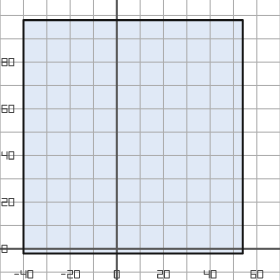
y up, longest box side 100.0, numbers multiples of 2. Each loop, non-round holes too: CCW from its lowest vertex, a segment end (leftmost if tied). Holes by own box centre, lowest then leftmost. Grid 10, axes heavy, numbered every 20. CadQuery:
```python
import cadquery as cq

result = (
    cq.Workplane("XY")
    .moveTo(-40.0, -2.0)
    .lineTo(54.0, -2.0)
    .lineTo(54.0, 98.0)
    .lineTo(-40.0, 98.0)
    .close()
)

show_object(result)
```